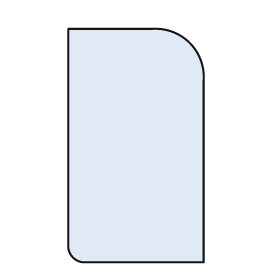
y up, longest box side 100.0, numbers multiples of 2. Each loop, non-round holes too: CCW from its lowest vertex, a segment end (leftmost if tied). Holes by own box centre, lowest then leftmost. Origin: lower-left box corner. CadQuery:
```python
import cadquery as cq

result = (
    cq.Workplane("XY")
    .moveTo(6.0, 0.0)
    .lineTo(58.0, 0.0)
    .lineTo(58.0, 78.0)
    .threePointArc((52.0, 94.0), (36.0, 100.0))
    .lineTo(0.0, 100.0)
    .lineTo(0.0, 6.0)
    .threePointArc((2.0, 2.0), (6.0, 0.0))
    .close()
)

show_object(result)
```